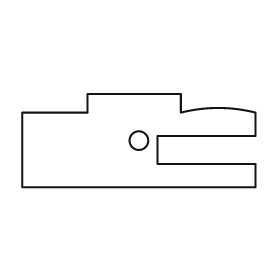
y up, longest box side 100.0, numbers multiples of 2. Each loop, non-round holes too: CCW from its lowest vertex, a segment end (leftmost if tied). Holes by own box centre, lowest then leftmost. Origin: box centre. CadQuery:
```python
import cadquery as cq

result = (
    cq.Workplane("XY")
    .moveTo(-50.0, -20.0)
    .lineTo(50.0, -20.0)
    .lineTo(50.0, -10.0)
    .lineTo(8.0, -10.0)
    .lineTo(8.0, 2.0)
    .lineTo(50.0, 2.0)
    .lineTo(50.0, 12.0)
    .threePointArc((34.0, 14.0), (18.0, 12.0))
    .lineTo(18.0, 20.0)
    .lineTo(-22.0, 20.0)
    .lineTo(-22.0, 12.0)
    .lineTo(-50.0, 12.0)
    .close()
    .moveTo(0.0, 0.0)
    .circle(4.0)
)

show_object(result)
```